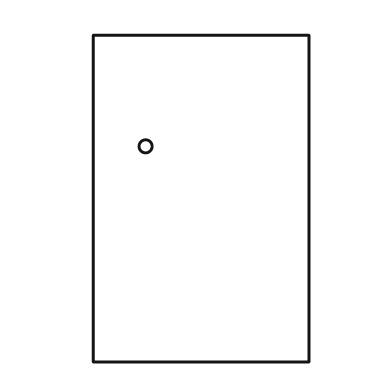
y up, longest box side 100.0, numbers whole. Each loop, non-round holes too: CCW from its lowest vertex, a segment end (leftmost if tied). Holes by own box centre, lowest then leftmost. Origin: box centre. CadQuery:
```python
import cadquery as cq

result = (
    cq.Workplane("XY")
    .moveTo(-33.0, -50.0)
    .lineTo(33.0, -50.0)
    .lineTo(33.0, 50.0)
    .lineTo(-33.0, 50.0)
    .close()
    .moveTo(-17.0, 16.0)
    .circle(2.0)
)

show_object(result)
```